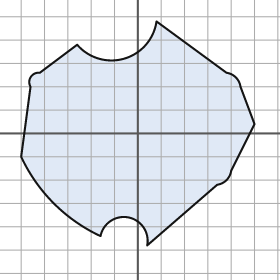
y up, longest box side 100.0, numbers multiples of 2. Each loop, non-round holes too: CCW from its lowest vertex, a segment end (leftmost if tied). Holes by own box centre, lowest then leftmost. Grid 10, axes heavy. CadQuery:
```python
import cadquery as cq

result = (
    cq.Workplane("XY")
    .moveTo(4.0, -48.0)
    .lineTo(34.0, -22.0)
    .threePointArc((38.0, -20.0), (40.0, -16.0))
    .lineTo(50.0, 4.0)
    .lineTo(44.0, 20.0)
    .threePointArc((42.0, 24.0), (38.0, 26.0))
    .lineTo(8.0, 48.0)
    .threePointArc((-6.0, 32.0), (-26.0, 38.0))
    .lineTo(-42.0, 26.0)
    .threePointArc((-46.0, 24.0), (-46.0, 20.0))
    .lineTo(-50.0, -10.0)
    .threePointArc((-36.0, -30.0), (-16.0, -44.0))
    .threePointArc((-4.0, -36.0), (4.0, -48.0))
    .close()
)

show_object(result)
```